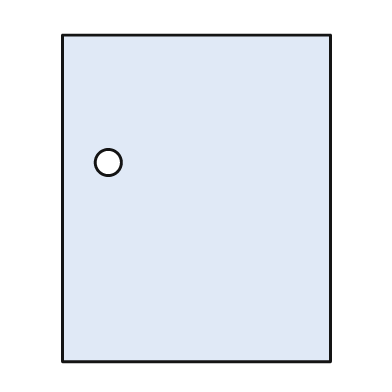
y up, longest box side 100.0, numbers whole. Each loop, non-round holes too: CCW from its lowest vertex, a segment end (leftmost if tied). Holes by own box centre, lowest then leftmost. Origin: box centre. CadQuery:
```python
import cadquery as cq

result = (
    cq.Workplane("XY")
    .moveTo(-41.0, -50.0)
    .lineTo(41.0, -50.0)
    .lineTo(41.0, 50.0)
    .lineTo(-41.0, 50.0)
    .close()
    .moveTo(-27.0, 11.0)
    .circle(4.0)
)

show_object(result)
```